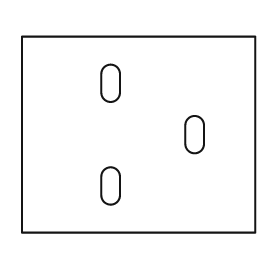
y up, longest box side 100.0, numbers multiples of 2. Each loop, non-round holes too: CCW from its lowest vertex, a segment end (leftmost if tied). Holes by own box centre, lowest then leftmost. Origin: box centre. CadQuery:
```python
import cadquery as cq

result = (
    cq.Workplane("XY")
    .moveTo(-50.0, -42.0)
    .lineTo(50.0, -42.0)
    .lineTo(50.0, 42.0)
    .lineTo(-50.0, 42.0)
    .close()
    .moveTo(-16.0, -26.0)
    .threePointArc((-12.0, -30.0), (-8.0, -26.0))
    .lineTo(-8.0, -18.0)
    .threePointArc((-12.0, -14.0), (-16.0, -18.0))
    .close()
    .moveTo(20.0, -4.0)
    .threePointArc((24.0, -8.0), (28.0, -4.0))
    .lineTo(28.0, 4.0)
    .threePointArc((24.0, 8.0), (20.0, 4.0))
    .close()
    .moveTo(-16.0, 18.0)
    .threePointArc((-12.0, 14.0), (-8.0, 18.0))
    .lineTo(-8.0, 26.0)
    .threePointArc((-12.0, 30.0), (-16.0, 26.0))
    .close()
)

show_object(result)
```